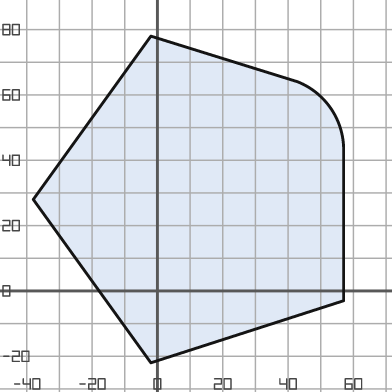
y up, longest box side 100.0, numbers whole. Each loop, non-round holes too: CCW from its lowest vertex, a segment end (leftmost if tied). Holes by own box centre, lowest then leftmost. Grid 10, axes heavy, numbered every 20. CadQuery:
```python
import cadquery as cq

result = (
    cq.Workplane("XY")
    .moveTo(-2.0, -22.0)
    .lineTo(57.0, -3.0)
    .lineTo(57.0, 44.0)
    .threePointArc((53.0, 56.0), (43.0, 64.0))
    .lineTo(-2.0, 78.0)
    .lineTo(-38.0, 28.0)
    .close()
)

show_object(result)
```